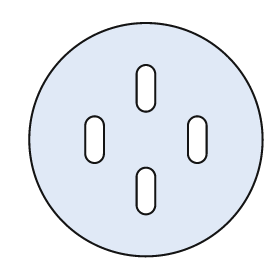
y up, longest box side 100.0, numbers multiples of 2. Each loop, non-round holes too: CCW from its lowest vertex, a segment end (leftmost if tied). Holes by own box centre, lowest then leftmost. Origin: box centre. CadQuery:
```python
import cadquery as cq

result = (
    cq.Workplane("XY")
    .moveTo(0.0, 0.0)
    .circle(50.0)
    .moveTo(-4.0, -28.0)
    .threePointArc((0.0, -32.0), (4.0, -28.0))
    .lineTo(4.0, -16.0)
    .threePointArc((0.0, -12.0), (-4.0, -16.0))
    .close()
    .moveTo(-26.0, -6.0)
    .threePointArc((-22.0, -10.0), (-18.0, -6.0))
    .lineTo(-18.0, 6.0)
    .threePointArc((-22.0, 10.0), (-26.0, 6.0))
    .close()
    .moveTo(18.0, -6.0)
    .threePointArc((22.0, -10.0), (26.0, -6.0))
    .lineTo(26.0, 6.0)
    .threePointArc((22.0, 10.0), (18.0, 6.0))
    .close()
    .moveTo(-4.0, 16.0)
    .threePointArc((0.0, 12.0), (4.0, 16.0))
    .lineTo(4.0, 28.0)
    .threePointArc((0.0, 32.0), (-4.0, 28.0))
    .close()
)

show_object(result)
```